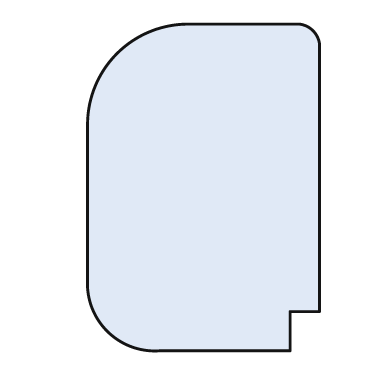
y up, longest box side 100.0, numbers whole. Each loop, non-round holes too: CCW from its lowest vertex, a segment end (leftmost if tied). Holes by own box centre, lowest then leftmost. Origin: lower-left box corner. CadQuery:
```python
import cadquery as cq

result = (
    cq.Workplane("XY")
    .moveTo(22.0, 0.0)
    .lineTo(62.0, 0.0)
    .lineTo(62.0, 12.0)
    .lineTo(71.0, 12.0)
    .lineTo(71.0, 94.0)
    .threePointArc((69.0, 98.0), (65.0, 100.0))
    .lineTo(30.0, 100.0)
    .threePointArc((9.0, 91.0), (0.0, 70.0))
    .lineTo(0.0, 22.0)
    .threePointArc((6.0, 6.0), (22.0, 0.0))
    .close()
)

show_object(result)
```